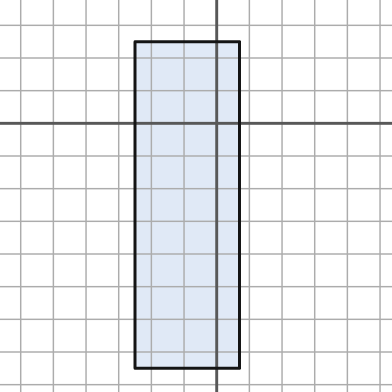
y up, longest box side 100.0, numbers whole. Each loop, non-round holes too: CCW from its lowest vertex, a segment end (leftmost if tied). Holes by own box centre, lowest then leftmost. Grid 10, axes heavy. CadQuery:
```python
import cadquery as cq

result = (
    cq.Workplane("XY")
    .moveTo(-25.0, -75.0)
    .lineTo(7.0, -75.0)
    .lineTo(7.0, 25.0)
    .lineTo(-25.0, 25.0)
    .close()
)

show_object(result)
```